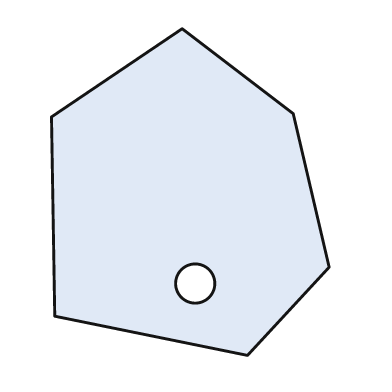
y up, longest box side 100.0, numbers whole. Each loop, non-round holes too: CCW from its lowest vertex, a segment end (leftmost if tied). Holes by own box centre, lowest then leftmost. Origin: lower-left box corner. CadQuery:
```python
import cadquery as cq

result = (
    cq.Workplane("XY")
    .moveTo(60.0, 0.0)
    .lineTo(85.0, 27.0)
    .lineTo(74.0, 74.0)
    .lineTo(40.0, 100.0)
    .lineTo(0.0, 73.0)
    .lineTo(1.0, 12.0)
    .close()
    .moveTo(44.0, 22.0)
    .circle(6.0)
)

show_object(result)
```